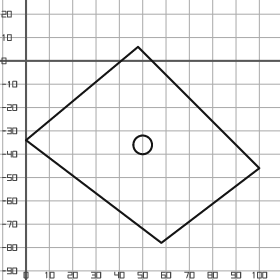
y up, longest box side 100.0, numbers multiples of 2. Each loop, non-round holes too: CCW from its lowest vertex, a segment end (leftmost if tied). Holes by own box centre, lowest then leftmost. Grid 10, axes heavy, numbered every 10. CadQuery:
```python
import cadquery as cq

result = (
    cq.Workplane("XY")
    .moveTo(58.0, -78.0)
    .lineTo(100.0, -46.0)
    .lineTo(48.0, 6.0)
    .lineTo(0.0, -34.0)
    .close()
    .moveTo(50.0, -36.0)
    .circle(4.0)
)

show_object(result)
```